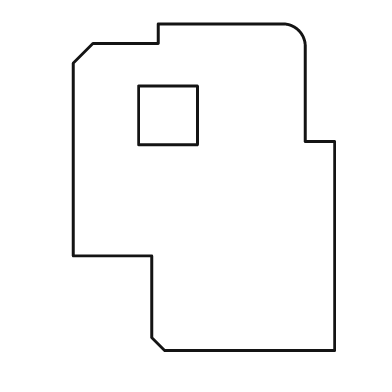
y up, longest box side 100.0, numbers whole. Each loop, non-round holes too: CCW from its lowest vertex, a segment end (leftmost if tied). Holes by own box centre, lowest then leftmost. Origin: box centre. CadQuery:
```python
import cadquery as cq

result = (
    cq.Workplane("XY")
    .moveTo(-12.0, -50.0)
    .lineTo(40.0, -50.0)
    .lineTo(40.0, 14.0)
    .lineTo(31.0, 14.0)
    .lineTo(31.0, 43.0)
    .threePointArc((29.0, 48.0), (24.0, 50.0))
    .lineTo(-14.0, 50.0)
    .lineTo(-14.0, 44.0)
    .lineTo(-34.0, 44.0)
    .lineTo(-40.0, 38.0)
    .lineTo(-40.0, -21.0)
    .lineTo(-16.0, -21.0)
    .lineTo(-16.0, -46.0)
    .close()
    .moveTo(-20.0, 13.0)
    .lineTo(-2.0, 13.0)
    .lineTo(-2.0, 31.0)
    .lineTo(-20.0, 31.0)
    .close()
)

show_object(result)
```